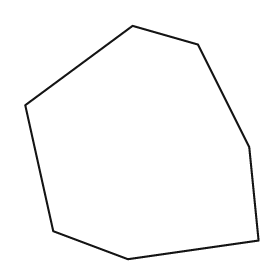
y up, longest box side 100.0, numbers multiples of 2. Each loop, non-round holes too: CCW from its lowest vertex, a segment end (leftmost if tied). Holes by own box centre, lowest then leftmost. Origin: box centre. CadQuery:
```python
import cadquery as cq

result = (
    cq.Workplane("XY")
    .moveTo(-6.0, -50.0)
    .lineTo(50.0, -42.0)
    .lineTo(46.0, -2.0)
    .lineTo(24.0, 42.0)
    .lineTo(-4.0, 50.0)
    .lineTo(-50.0, 16.0)
    .lineTo(-38.0, -38.0)
    .close()
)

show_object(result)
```